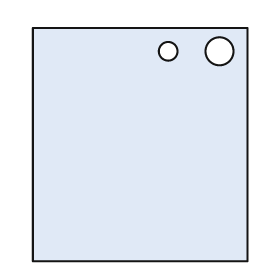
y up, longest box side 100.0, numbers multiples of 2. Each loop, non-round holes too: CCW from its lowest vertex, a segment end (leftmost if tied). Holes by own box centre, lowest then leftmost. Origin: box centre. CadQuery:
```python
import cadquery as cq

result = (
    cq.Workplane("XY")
    .moveTo(-46.0, -50.0)
    .lineTo(46.0, -50.0)
    .lineTo(46.0, 50.0)
    .lineTo(-46.0, 50.0)
    .close()
    .moveTo(12.0, 40.0)
    .circle(4.0)
    .moveTo(34.0, 40.0)
    .circle(6.0)
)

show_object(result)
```